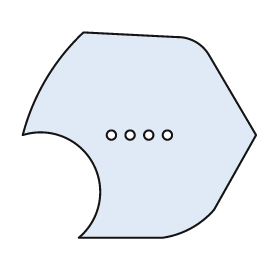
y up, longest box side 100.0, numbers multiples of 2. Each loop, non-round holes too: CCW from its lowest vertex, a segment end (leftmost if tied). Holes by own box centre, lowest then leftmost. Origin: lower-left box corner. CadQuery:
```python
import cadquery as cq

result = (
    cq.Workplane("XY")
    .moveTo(24.0, 0.0)
    .lineTo(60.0, 0.0)
    .threePointArc((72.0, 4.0), (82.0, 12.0))
    .lineTo(100.0, 44.0)
    .lineTo(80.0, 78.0)
    .threePointArc((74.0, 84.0), (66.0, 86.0))
    .lineTo(26.0, 88.0)
    .threePointArc((10.0, 68.0), (0.0, 44.0))
    .threePointArc((30.0, 32.0), (24.0, 0.0))
    .close()
    .moveTo(38.0, 44.0)
    .circle(2.0)
    .moveTo(46.0, 44.0)
    .circle(2.0)
    .moveTo(54.0, 44.0)
    .circle(2.0)
    .moveTo(62.0, 44.0)
    .circle(2.0)
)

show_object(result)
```